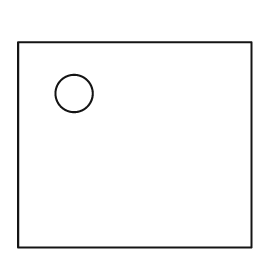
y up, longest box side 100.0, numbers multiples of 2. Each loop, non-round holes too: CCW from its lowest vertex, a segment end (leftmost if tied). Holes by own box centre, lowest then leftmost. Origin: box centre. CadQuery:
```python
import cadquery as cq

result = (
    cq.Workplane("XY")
    .moveTo(-50.0, -44.0)
    .lineTo(50.0, -44.0)
    .lineTo(50.0, 44.0)
    .lineTo(-50.0, 44.0)
    .close()
    .moveTo(-26.0, 22.0)
    .circle(8.0)
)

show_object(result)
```